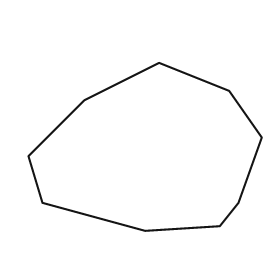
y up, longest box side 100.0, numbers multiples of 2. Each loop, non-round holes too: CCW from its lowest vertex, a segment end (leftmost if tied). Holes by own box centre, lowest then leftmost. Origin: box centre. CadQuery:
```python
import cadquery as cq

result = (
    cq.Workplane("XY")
    .moveTo(0.0, -36.0)
    .lineTo(32.0, -34.0)
    .lineTo(40.0, -24.0)
    .lineTo(50.0, 4.0)
    .lineTo(36.0, 24.0)
    .lineTo(6.0, 36.0)
    .lineTo(-26.0, 20.0)
    .lineTo(-50.0, -4.0)
    .lineTo(-44.0, -24.0)
    .close()
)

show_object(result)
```